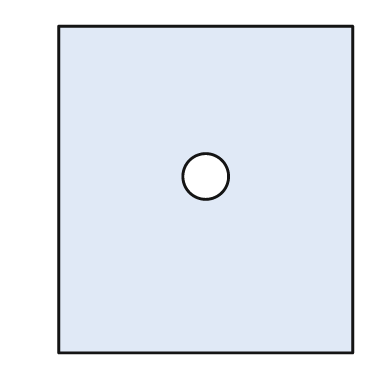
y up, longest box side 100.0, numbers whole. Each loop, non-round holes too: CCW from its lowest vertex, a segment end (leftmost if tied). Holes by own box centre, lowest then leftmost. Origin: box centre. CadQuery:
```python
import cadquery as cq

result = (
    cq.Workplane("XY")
    .moveTo(-45.0, -50.0)
    .lineTo(45.0, -50.0)
    .lineTo(45.0, 50.0)
    .lineTo(-45.0, 50.0)
    .close()
    .moveTo(0.0, 4.0)
    .circle(7.0)
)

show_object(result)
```